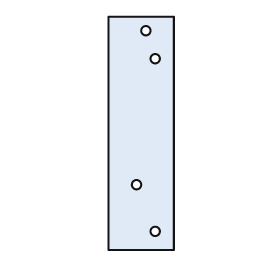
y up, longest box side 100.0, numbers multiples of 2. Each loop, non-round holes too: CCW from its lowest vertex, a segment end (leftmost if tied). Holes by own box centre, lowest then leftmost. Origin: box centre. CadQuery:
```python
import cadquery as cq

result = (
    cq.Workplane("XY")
    .moveTo(-14.0, -50.0)
    .lineTo(14.0, -50.0)
    .lineTo(14.0, 50.0)
    .lineTo(-14.0, 50.0)
    .close()
    .moveTo(6.0, -42.0)
    .circle(2.0)
    .moveTo(-2.0, -22.0)
    .circle(2.0)
    .moveTo(6.0, 32.0)
    .circle(2.0)
    .moveTo(2.0, 44.0)
    .circle(2.0)
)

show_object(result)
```